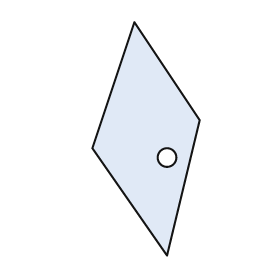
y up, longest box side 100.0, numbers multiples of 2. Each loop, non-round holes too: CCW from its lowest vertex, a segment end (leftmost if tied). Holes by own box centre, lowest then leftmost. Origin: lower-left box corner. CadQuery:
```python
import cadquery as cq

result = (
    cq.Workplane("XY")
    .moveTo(32.0, 0.0)
    .lineTo(46.0, 58.0)
    .lineTo(18.0, 100.0)
    .lineTo(0.0, 46.0)
    .close()
    .moveTo(32.0, 42.0)
    .circle(4.0)
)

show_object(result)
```